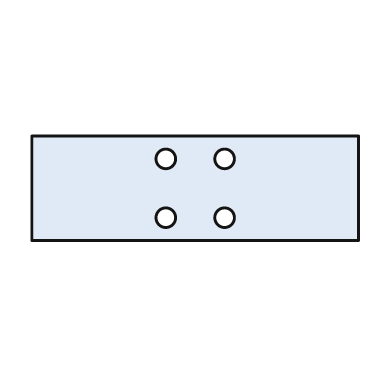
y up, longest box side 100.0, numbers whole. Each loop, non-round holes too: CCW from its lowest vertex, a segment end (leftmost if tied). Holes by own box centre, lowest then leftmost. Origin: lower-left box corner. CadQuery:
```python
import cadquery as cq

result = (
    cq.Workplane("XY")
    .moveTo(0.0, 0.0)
    .lineTo(100.0, 0.0)
    .lineTo(100.0, 32.0)
    .lineTo(0.0, 32.0)
    .close()
    .moveTo(41.0, 7.0)
    .circle(3.0)
    .moveTo(59.0, 7.0)
    .circle(3.0)
    .moveTo(41.0, 25.0)
    .circle(3.0)
    .moveTo(59.0, 25.0)
    .circle(3.0)
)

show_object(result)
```